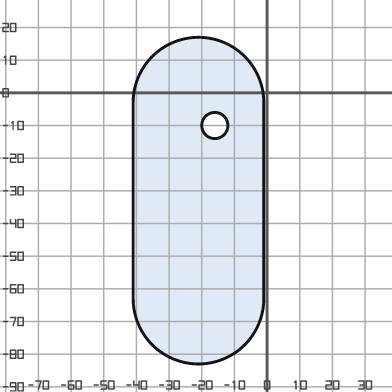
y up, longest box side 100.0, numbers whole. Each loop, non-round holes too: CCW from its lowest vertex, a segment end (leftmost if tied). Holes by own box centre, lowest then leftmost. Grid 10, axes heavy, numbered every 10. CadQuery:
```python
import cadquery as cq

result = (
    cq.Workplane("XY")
    .moveTo(-41.0, -63.0)
    .threePointArc((-21.0, -83.0), (-1.0, -63.0))
    .lineTo(-1.0, -3.0)
    .threePointArc((-21.0, 17.0), (-41.0, -3.0))
    .close()
    .moveTo(-16.0, -10.0)
    .circle(4.0)
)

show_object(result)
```